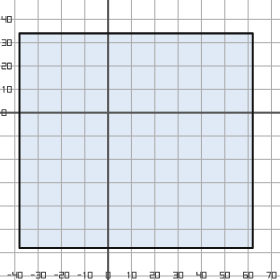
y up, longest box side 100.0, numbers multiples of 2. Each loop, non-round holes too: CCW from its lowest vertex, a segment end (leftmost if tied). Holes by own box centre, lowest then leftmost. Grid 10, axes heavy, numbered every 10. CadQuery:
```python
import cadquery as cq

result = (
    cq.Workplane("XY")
    .moveTo(-38.0, -58.0)
    .lineTo(62.0, -58.0)
    .lineTo(62.0, 34.0)
    .lineTo(-38.0, 34.0)
    .close()
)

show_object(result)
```